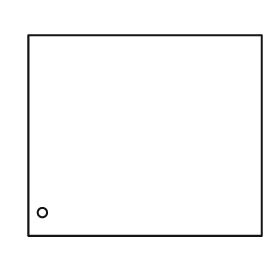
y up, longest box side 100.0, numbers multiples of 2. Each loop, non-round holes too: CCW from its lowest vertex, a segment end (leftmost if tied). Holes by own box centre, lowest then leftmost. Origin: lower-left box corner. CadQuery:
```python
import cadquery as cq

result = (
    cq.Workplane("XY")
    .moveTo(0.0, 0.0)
    .lineTo(100.0, 0.0)
    .lineTo(100.0, 86.0)
    .lineTo(0.0, 86.0)
    .close()
    .moveTo(6.0, 10.0)
    .circle(2.0)
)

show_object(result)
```